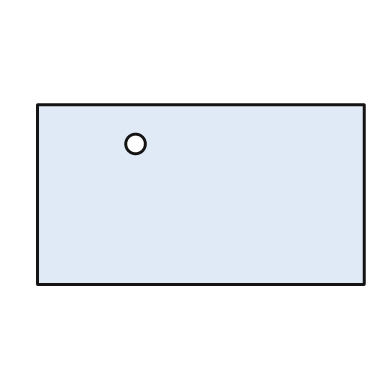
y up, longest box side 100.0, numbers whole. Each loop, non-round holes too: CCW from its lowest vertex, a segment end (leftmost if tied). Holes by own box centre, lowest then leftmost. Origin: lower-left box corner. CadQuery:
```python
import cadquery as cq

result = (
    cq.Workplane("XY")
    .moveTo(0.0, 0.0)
    .lineTo(100.0, 0.0)
    .lineTo(100.0, 55.0)
    .lineTo(0.0, 55.0)
    .close()
    .moveTo(30.0, 43.0)
    .circle(3.0)
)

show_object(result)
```